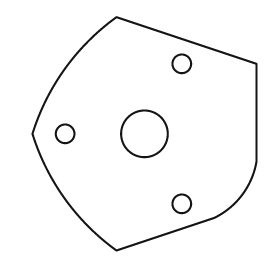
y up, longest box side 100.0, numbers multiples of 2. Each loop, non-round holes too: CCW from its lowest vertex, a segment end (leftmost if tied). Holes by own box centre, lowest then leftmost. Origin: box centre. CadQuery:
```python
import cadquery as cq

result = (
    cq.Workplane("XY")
    .moveTo(-12.0, -50.0)
    .lineTo(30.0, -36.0)
    .threePointArc((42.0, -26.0), (48.0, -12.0))
    .lineTo(48.0, 30.0)
    .lineTo(-12.0, 50.0)
    .threePointArc((-34.0, 28.0), (-48.0, 0.0))
    .threePointArc((-34.0, -28.0), (-12.0, -50.0))
    .close()
    .moveTo(16.0, -30.0)
    .circle(4.0)
    .moveTo(-34.0, 0.0)
    .circle(4.0)
    .moveTo(0.0, 0.0)
    .circle(10.0)
    .moveTo(16.0, 30.0)
    .circle(4.0)
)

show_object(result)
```